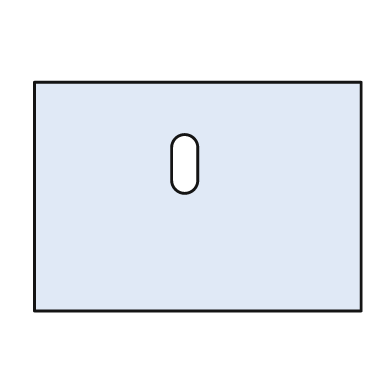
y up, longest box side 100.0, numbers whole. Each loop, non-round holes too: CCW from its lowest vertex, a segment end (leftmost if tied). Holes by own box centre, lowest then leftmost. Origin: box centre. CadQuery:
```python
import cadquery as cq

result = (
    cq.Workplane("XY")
    .moveTo(-50.0, -35.0)
    .lineTo(50.0, -35.0)
    .lineTo(50.0, 35.0)
    .lineTo(-50.0, 35.0)
    .close()
    .moveTo(-8.0, 5.0)
    .threePointArc((-4.0, 1.0), (0.0, 5.0))
    .lineTo(0.0, 15.0)
    .threePointArc((-4.0, 19.0), (-8.0, 15.0))
    .close()
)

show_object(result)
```